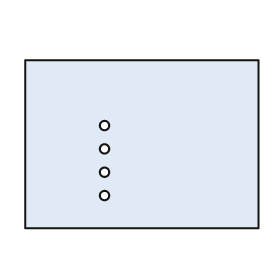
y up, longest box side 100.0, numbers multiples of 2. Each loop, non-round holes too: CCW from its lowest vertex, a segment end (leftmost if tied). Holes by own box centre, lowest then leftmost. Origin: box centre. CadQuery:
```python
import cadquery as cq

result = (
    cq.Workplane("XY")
    .moveTo(-50.0, -36.0)
    .lineTo(50.0, -36.0)
    .lineTo(50.0, 36.0)
    .lineTo(-50.0, 36.0)
    .close()
    .moveTo(-16.0, -22.0)
    .circle(2.0)
    .moveTo(-16.0, -12.0)
    .circle(2.0)
    .moveTo(-16.0, -2.0)
    .circle(2.0)
    .moveTo(-16.0, 8.0)
    .circle(2.0)
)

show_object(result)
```